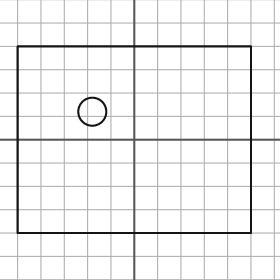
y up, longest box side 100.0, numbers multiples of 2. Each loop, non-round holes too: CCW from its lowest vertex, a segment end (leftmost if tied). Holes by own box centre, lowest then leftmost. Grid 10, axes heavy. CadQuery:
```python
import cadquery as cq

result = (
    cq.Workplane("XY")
    .moveTo(-50.0, -40.0)
    .lineTo(50.0, -40.0)
    .lineTo(50.0, 40.0)
    .lineTo(-50.0, 40.0)
    .close()
    .moveTo(-18.0, 12.0)
    .circle(6.0)
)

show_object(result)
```